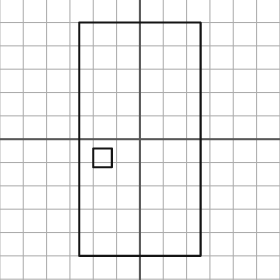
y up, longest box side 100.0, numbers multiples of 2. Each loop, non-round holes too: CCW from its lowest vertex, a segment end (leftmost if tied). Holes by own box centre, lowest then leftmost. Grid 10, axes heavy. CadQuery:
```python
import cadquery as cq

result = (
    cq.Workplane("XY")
    .moveTo(-26.0, -50.0)
    .lineTo(26.0, -50.0)
    .lineTo(26.0, 50.0)
    .lineTo(-26.0, 50.0)
    .close()
    .moveTo(-20.0, -12.0)
    .lineTo(-12.0, -12.0)
    .lineTo(-12.0, -4.0)
    .lineTo(-20.0, -4.0)
    .close()
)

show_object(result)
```